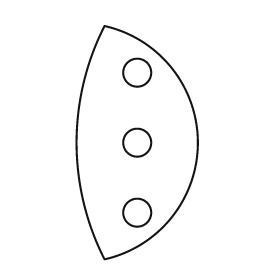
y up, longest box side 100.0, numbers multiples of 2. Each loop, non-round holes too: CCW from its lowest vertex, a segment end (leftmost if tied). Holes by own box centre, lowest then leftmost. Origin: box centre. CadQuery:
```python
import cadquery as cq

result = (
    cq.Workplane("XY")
    .moveTo(-14.0, -50.0)
    .threePointArc((26.0, 0.0), (-14.0, 50.0))
    .threePointArc((-26.0, 0.0), (-14.0, -50.0))
    .close()
    .moveTo(0.0, -30.0)
    .circle(6.0)
    .moveTo(0.0, 0.0)
    .circle(6.0)
    .moveTo(0.0, 30.0)
    .circle(6.0)
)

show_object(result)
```